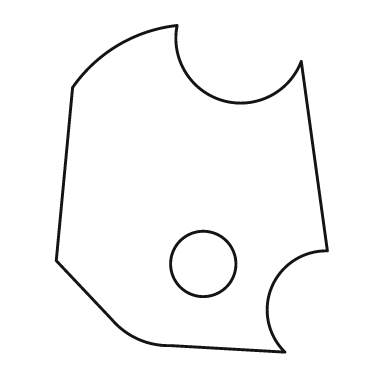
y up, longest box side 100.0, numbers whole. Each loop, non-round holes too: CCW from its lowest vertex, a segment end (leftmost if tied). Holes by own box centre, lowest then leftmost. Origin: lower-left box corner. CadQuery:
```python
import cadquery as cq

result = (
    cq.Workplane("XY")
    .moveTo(70.0, 0.0)
    .threePointArc((66.0, 20.0), (83.0, 31.0))
    .lineTo(75.0, 89.0)
    .threePointArc((51.0, 77.0), (37.0, 100.0))
    .threePointArc((19.0, 94.0), (5.0, 81.0))
    .lineTo(0.0, 28.0)
    .lineTo(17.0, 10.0)
    .threePointArc((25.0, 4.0), (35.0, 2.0))
    .close()
    .moveTo(45.0, 27.0)
    .circle(10.0)
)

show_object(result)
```